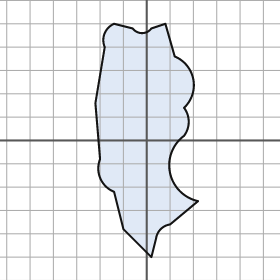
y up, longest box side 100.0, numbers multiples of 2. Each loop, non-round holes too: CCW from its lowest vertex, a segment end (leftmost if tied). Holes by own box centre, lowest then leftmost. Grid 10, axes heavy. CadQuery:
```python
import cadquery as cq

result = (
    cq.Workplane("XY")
    .moveTo(2.0, -50.0)
    .lineTo(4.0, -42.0)
    .threePointArc((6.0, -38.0), (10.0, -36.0))
    .lineTo(22.0, -26.0)
    .threePointArc((10.0, -14.0), (16.0, 2.0))
    .threePointArc((18.0, 8.0), (16.0, 14.0))
    .threePointArc((20.0, 26.0), (12.0, 36.0))
    .lineTo(8.0, 50.0)
    .lineTo(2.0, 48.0)
    .threePointArc((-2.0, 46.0), (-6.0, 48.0))
    .lineTo(-14.0, 50.0)
    .threePointArc((-18.0, 46.0), (-18.0, 40.0))
    .lineTo(-22.0, 16.0)
    .lineTo(-20.0, -8.0)
    .threePointArc((-20.0, -16.0), (-14.0, -22.0))
    .lineTo(-10.0, -38.0)
    .close()
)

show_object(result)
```